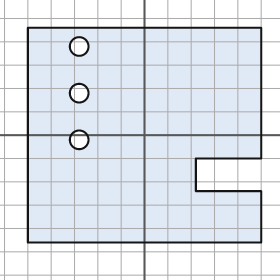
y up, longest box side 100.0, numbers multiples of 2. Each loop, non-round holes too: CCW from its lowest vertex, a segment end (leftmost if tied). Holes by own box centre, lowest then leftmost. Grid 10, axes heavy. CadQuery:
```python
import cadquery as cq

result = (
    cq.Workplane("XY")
    .moveTo(-50.0, -46.0)
    .lineTo(50.0, -46.0)
    .lineTo(50.0, -24.0)
    .lineTo(22.0, -24.0)
    .lineTo(22.0, -10.0)
    .lineTo(50.0, -10.0)
    .lineTo(50.0, 46.0)
    .lineTo(-50.0, 46.0)
    .close()
    .moveTo(-28.0, -2.0)
    .circle(4.0)
    .moveTo(-28.0, 18.0)
    .circle(4.0)
    .moveTo(-28.0, 38.0)
    .circle(4.0)
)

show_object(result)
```